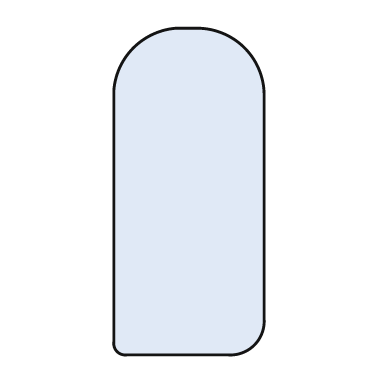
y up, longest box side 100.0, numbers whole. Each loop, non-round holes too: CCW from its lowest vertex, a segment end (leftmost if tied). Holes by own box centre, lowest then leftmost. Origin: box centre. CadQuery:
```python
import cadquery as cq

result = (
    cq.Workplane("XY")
    .moveTo(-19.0, -50.0)
    .lineTo(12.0, -50.0)
    .threePointArc((20.0, -47.0), (23.0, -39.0))
    .lineTo(23.0, 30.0)
    .threePointArc((17.0, 44.0), (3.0, 50.0))
    .lineTo(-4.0, 50.0)
    .threePointArc((-17.0, 44.0), (-23.0, 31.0))
    .lineTo(-23.0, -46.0)
    .threePointArc((-22.0, -49.0), (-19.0, -50.0))
    .close()
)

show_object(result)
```